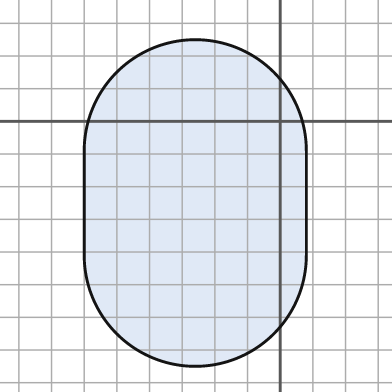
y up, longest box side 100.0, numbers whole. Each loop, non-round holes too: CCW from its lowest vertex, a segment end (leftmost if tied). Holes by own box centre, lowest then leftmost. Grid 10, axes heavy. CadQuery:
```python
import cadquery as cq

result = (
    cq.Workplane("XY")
    .moveTo(-60.0, -41.0)
    .threePointArc((-26.0, -75.0), (8.0, -41.0))
    .lineTo(8.0, -9.0)
    .threePointArc((-26.0, 25.0), (-60.0, -9.0))
    .close()
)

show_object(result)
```